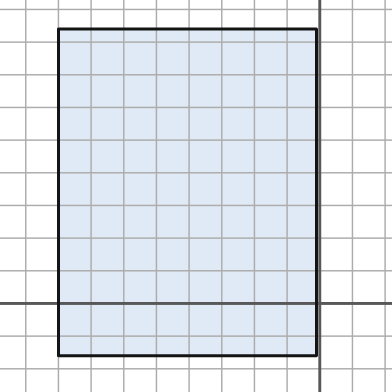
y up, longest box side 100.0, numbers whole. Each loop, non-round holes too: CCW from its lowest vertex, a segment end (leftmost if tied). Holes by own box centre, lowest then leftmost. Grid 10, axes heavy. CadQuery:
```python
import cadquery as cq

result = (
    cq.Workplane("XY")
    .moveTo(-80.0, -16.0)
    .lineTo(-1.0, -16.0)
    .lineTo(-1.0, 84.0)
    .lineTo(-80.0, 84.0)
    .close()
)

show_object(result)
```